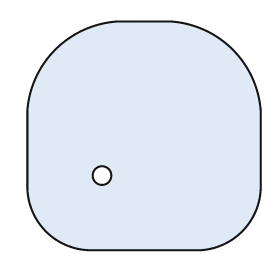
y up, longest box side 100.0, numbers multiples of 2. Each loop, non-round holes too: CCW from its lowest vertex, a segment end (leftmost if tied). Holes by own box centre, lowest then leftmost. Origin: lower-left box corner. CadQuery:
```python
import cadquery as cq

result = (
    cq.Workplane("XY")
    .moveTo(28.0, 0.0)
    .lineTo(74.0, 0.0)
    .threePointArc((92.0, 8.0), (100.0, 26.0))
    .lineTo(100.0, 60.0)
    .threePointArc((88.0, 86.0), (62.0, 98.0))
    .lineTo(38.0, 98.0)
    .threePointArc((12.0, 86.0), (0.0, 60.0))
    .lineTo(0.0, 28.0)
    .threePointArc((8.0, 8.0), (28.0, 0.0))
    .close()
    .moveTo(32.0, 32.0)
    .circle(4.0)
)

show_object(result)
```